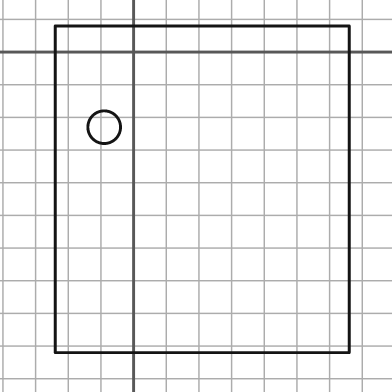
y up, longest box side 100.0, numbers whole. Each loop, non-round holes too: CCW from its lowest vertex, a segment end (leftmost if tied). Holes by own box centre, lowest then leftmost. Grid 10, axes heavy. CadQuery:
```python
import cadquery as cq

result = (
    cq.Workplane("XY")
    .moveTo(-24.0, -92.0)
    .lineTo(66.0, -92.0)
    .lineTo(66.0, 8.0)
    .lineTo(-24.0, 8.0)
    .close()
    .moveTo(-9.0, -23.0)
    .circle(5.0)
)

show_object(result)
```